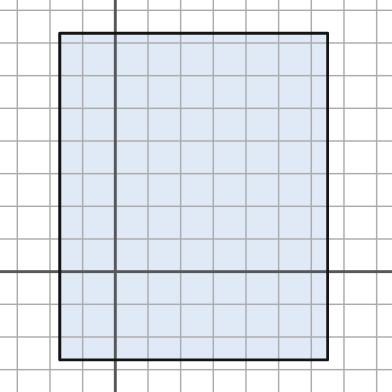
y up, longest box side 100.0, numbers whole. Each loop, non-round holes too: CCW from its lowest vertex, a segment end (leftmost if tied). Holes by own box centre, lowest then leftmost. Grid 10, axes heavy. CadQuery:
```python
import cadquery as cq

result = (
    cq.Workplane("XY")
    .moveTo(-17.0, -27.0)
    .lineTo(65.0, -27.0)
    .lineTo(65.0, 73.0)
    .lineTo(-17.0, 73.0)
    .close()
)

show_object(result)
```